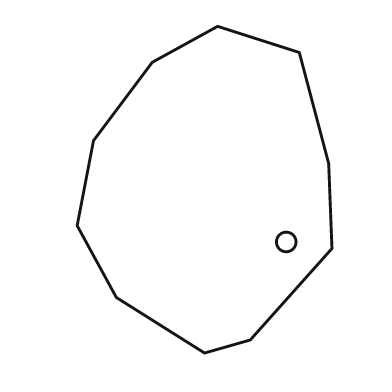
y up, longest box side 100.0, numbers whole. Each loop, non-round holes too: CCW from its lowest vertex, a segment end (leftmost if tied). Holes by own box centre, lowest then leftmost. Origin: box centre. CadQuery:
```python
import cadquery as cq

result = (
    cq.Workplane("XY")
    .moveTo(0.0, -50.0)
    .lineTo(14.0, -46.0)
    .lineTo(39.0, -18.0)
    .lineTo(38.0, 8.0)
    .lineTo(29.0, 42.0)
    .lineTo(4.0, 50.0)
    .lineTo(-16.0, 39.0)
    .lineTo(-34.0, 15.0)
    .lineTo(-39.0, -11.0)
    .lineTo(-27.0, -33.0)
    .close()
    .moveTo(25.0, -16.0)
    .circle(3.0)
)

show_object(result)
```